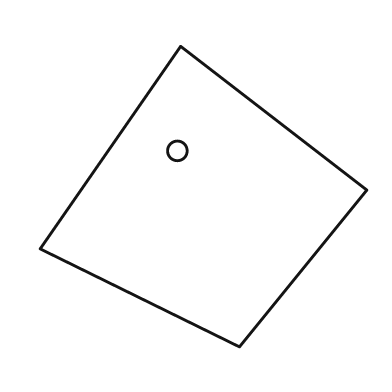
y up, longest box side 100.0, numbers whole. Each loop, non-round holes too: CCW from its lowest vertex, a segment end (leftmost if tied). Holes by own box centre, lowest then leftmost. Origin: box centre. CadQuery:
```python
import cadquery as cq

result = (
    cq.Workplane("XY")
    .moveTo(11.0, -46.0)
    .lineTo(50.0, 2.0)
    .lineTo(-7.0, 46.0)
    .lineTo(-50.0, -16.0)
    .close()
    .moveTo(-8.0, 14.0)
    .circle(3.0)
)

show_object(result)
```